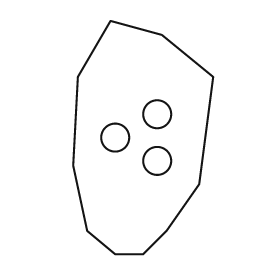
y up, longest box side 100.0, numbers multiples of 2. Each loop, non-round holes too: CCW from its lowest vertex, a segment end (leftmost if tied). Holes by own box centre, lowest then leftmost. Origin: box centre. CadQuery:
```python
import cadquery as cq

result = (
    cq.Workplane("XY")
    .moveTo(-12.0, -50.0)
    .lineTo(0.0, -50.0)
    .lineTo(10.0, -40.0)
    .lineTo(24.0, -20.0)
    .lineTo(30.0, 26.0)
    .lineTo(8.0, 44.0)
    .lineTo(-14.0, 50.0)
    .lineTo(-28.0, 26.0)
    .lineTo(-30.0, -12.0)
    .lineTo(-24.0, -40.0)
    .close()
    .moveTo(6.0, -10.0)
    .circle(6.0)
    .moveTo(-12.0, 0.0)
    .circle(6.0)
    .moveTo(6.0, 10.0)
    .circle(6.0)
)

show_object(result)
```